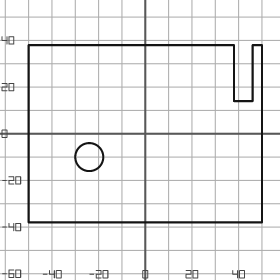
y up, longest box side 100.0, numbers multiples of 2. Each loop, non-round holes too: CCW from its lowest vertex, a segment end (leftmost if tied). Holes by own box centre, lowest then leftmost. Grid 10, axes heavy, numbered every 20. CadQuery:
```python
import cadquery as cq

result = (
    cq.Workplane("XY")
    .moveTo(-50.0, -38.0)
    .lineTo(50.0, -38.0)
    .lineTo(50.0, 38.0)
    .lineTo(46.0, 38.0)
    .lineTo(46.0, 14.0)
    .lineTo(38.0, 14.0)
    .lineTo(38.0, 38.0)
    .lineTo(-50.0, 38.0)
    .close()
    .moveTo(-24.0, -10.0)
    .circle(6.0)
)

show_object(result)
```